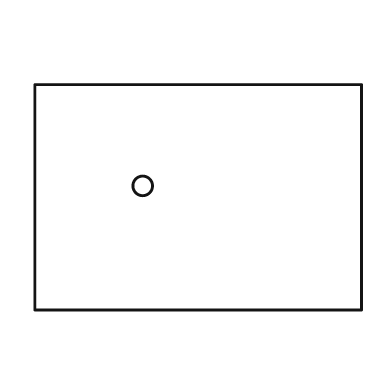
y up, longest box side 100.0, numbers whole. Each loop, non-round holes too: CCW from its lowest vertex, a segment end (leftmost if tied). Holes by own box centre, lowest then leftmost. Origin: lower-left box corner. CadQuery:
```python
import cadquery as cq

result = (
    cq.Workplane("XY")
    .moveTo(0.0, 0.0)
    .lineTo(100.0, 0.0)
    .lineTo(100.0, 69.0)
    .lineTo(0.0, 69.0)
    .close()
    .moveTo(33.0, 38.0)
    .circle(3.0)
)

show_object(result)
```